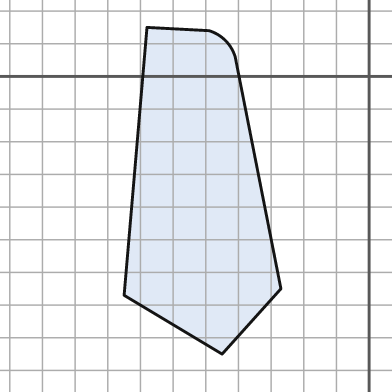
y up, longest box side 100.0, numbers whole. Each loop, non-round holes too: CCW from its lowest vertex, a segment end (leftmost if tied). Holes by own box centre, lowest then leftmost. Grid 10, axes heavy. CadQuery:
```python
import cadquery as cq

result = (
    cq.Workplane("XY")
    .moveTo(-45.0, -85.0)
    .lineTo(-27.0, -65.0)
    .lineTo(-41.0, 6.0)
    .threePointArc((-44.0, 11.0), (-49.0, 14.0))
    .lineTo(-68.0, 15.0)
    .lineTo(-75.0, -67.0)
    .close()
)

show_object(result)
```